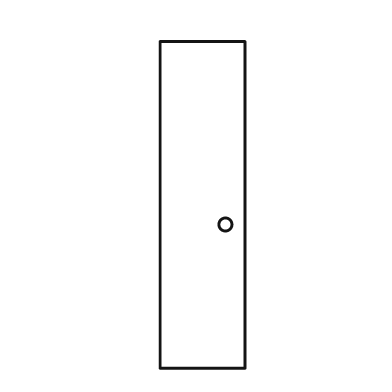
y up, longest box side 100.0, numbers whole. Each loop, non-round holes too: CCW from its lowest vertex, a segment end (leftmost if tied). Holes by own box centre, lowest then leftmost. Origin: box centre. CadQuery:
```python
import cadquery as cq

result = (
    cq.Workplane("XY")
    .moveTo(-13.0, -50.0)
    .lineTo(13.0, -50.0)
    .lineTo(13.0, 50.0)
    .lineTo(-13.0, 50.0)
    .close()
    .moveTo(7.0, -6.0)
    .circle(2.0)
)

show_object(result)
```